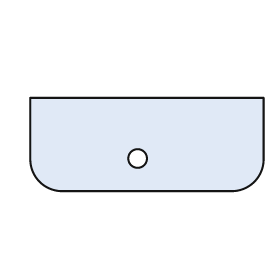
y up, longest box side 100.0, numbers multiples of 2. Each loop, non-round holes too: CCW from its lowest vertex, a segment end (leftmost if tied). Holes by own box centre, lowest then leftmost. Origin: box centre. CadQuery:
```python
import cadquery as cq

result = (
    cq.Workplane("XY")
    .moveTo(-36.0, -20.0)
    .lineTo(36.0, -20.0)
    .threePointArc((46.0, -16.0), (50.0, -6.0))
    .lineTo(50.0, 20.0)
    .lineTo(-50.0, 20.0)
    .lineTo(-50.0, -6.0)
    .threePointArc((-46.0, -16.0), (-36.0, -20.0))
    .close()
    .moveTo(-4.0, -6.0)
    .circle(4.0)
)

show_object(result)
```